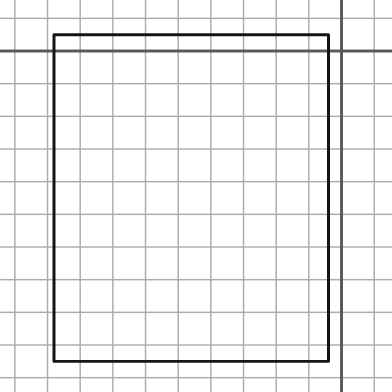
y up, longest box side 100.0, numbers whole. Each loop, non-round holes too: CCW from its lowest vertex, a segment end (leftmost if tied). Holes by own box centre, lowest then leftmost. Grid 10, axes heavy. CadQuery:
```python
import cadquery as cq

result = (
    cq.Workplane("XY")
    .moveTo(-88.0, -95.0)
    .lineTo(-4.0, -95.0)
    .lineTo(-4.0, 5.0)
    .lineTo(-88.0, 5.0)
    .close()
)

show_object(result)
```